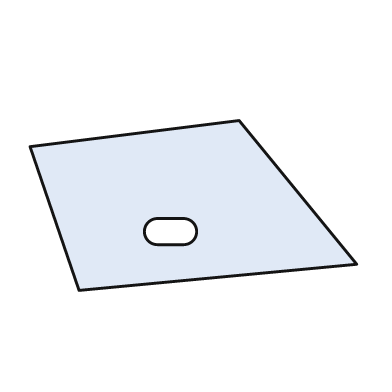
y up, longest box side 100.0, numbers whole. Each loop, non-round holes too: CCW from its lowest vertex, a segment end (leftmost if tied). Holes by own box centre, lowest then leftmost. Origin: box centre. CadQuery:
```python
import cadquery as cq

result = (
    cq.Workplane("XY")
    .moveTo(-35.0, -26.0)
    .lineTo(50.0, -18.0)
    .lineTo(14.0, 26.0)
    .lineTo(-50.0, 18.0)
    .close()
    .moveTo(-11.0, -12.0)
    .lineTo(-3.0, -12.0)
    .threePointArc((1.0, -8.0), (-3.0, -4.0))
    .lineTo(-11.0, -4.0)
    .threePointArc((-15.0, -8.0), (-11.0, -12.0))
    .close()
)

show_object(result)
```